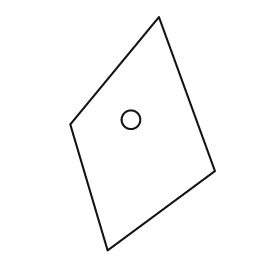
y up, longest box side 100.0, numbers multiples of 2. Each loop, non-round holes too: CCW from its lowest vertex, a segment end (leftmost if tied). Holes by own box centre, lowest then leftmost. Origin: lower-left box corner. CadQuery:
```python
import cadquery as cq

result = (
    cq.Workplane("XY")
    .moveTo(16.0, 0.0)
    .lineTo(62.0, 34.0)
    .lineTo(38.0, 100.0)
    .lineTo(0.0, 54.0)
    .close()
    .moveTo(26.0, 56.0)
    .circle(4.0)
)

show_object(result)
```